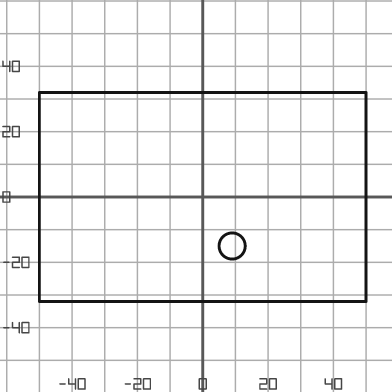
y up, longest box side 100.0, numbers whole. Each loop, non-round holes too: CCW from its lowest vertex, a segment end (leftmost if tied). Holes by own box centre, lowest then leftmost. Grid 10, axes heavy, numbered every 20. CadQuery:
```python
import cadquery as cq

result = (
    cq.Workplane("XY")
    .moveTo(-50.0, -32.0)
    .lineTo(50.0, -32.0)
    .lineTo(50.0, 32.0)
    .lineTo(-50.0, 32.0)
    .close()
    .moveTo(9.0, -15.0)
    .circle(4.0)
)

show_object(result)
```